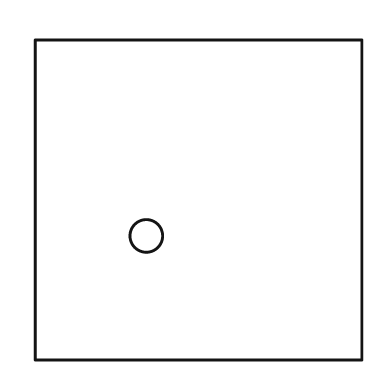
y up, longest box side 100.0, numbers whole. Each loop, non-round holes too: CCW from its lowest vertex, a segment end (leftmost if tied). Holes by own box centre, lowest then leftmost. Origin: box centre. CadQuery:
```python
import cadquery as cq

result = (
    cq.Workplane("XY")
    .moveTo(-50.0, -49.0)
    .lineTo(50.0, -49.0)
    .lineTo(50.0, 49.0)
    .lineTo(-50.0, 49.0)
    .close()
    .moveTo(-16.0, -11.0)
    .circle(5.0)
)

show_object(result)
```